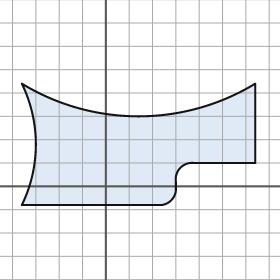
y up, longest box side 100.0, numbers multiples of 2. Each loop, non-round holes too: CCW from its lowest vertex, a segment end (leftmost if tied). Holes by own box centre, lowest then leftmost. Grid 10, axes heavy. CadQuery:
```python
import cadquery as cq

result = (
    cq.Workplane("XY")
    .moveTo(-36.0, -8.0)
    .lineTo(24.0, -8.0)
    .threePointArc((28.0, -6.0), (30.0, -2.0))
    .lineTo(30.0, 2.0)
    .threePointArc((32.0, 8.0), (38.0, 10.0))
    .lineTo(64.0, 10.0)
    .lineTo(64.0, 44.0)
    .threePointArc((14.0, 30.0), (-36.0, 44.0))
    .threePointArc((-30.0, 18.0), (-36.0, -8.0))
    .close()
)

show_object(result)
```